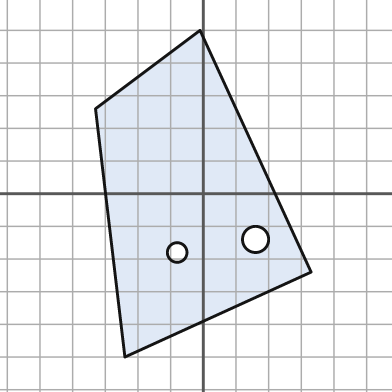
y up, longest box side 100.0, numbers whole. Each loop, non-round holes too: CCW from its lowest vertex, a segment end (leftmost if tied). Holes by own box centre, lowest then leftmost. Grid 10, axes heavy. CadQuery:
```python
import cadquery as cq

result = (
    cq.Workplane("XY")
    .moveTo(-24.0, -50.0)
    .lineTo(33.0, -24.0)
    .lineTo(-1.0, 50.0)
    .lineTo(-33.0, 26.0)
    .close()
    .moveTo(-8.0, -18.0)
    .circle(3.0)
    .moveTo(16.0, -14.0)
    .circle(4.0)
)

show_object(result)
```